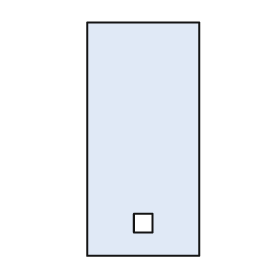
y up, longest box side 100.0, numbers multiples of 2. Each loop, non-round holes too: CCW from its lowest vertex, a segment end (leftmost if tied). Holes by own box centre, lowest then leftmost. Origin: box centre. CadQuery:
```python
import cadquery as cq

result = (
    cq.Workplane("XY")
    .moveTo(-24.0, -50.0)
    .lineTo(24.0, -50.0)
    .lineTo(24.0, 50.0)
    .lineTo(-24.0, 50.0)
    .close()
    .moveTo(-4.0, -40.0)
    .lineTo(4.0, -40.0)
    .lineTo(4.0, -32.0)
    .lineTo(-4.0, -32.0)
    .close()
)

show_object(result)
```